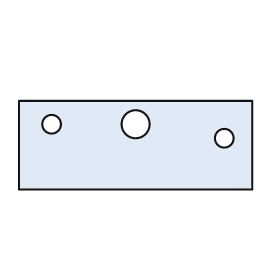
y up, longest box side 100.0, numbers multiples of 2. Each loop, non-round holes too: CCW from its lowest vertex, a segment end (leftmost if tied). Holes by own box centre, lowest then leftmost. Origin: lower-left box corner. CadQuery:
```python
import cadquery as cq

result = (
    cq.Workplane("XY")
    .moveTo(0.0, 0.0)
    .lineTo(100.0, 0.0)
    .lineTo(100.0, 38.0)
    .lineTo(0.0, 38.0)
    .close()
    .moveTo(88.0, 22.0)
    .circle(4.0)
    .moveTo(14.0, 28.0)
    .circle(4.0)
    .moveTo(50.0, 28.0)
    .circle(6.0)
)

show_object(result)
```